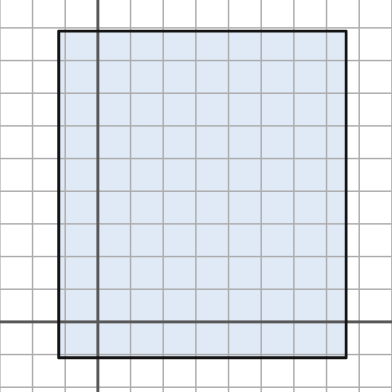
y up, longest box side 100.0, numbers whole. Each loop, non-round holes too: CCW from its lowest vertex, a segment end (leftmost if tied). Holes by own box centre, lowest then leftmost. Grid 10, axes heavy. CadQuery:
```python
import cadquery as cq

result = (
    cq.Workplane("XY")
    .moveTo(-12.0, -11.0)
    .lineTo(76.0, -11.0)
    .lineTo(76.0, 89.0)
    .lineTo(-12.0, 89.0)
    .close()
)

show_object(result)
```